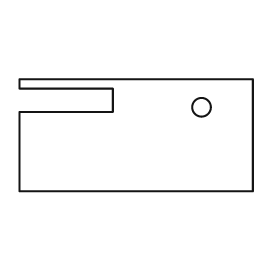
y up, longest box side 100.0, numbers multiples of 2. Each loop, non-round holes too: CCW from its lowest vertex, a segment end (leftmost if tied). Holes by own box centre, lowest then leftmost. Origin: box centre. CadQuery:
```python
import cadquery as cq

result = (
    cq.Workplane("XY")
    .moveTo(-50.0, -24.0)
    .lineTo(50.0, -24.0)
    .lineTo(50.0, 24.0)
    .lineTo(-50.0, 24.0)
    .lineTo(-50.0, 20.0)
    .lineTo(-10.0, 20.0)
    .lineTo(-10.0, 10.0)
    .lineTo(-50.0, 10.0)
    .close()
    .moveTo(28.0, 12.0)
    .circle(4.0)
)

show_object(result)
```